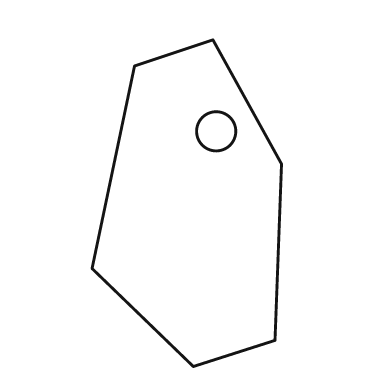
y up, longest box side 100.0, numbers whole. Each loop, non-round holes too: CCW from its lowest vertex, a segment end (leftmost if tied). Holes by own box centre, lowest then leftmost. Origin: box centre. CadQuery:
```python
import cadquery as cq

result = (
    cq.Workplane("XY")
    .moveTo(2.0, -50.0)
    .lineTo(27.0, -42.0)
    .lineTo(29.0, 12.0)
    .lineTo(8.0, 50.0)
    .lineTo(-16.0, 42.0)
    .lineTo(-29.0, -20.0)
    .close()
    .moveTo(9.0, 22.0)
    .circle(6.0)
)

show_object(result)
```